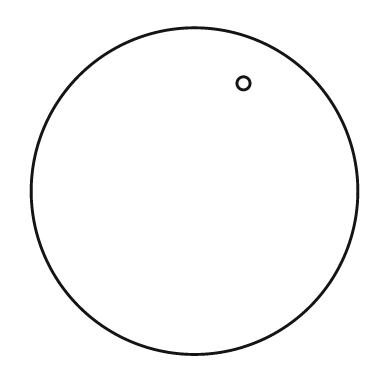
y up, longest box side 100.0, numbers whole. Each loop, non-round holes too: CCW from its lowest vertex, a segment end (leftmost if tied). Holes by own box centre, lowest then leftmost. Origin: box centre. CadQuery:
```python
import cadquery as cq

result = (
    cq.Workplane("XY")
    .moveTo(0.0, 0.0)
    .circle(50.0)
    .moveTo(15.0, 33.0)
    .circle(2.0)
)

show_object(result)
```